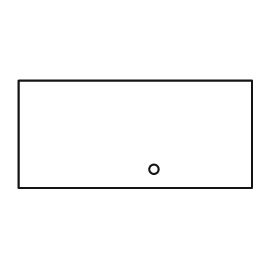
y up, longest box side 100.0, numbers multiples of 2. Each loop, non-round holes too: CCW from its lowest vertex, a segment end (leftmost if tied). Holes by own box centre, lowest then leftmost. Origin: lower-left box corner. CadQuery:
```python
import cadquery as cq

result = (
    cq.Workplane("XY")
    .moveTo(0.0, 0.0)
    .lineTo(100.0, 0.0)
    .lineTo(100.0, 46.0)
    .lineTo(0.0, 46.0)
    .close()
    .moveTo(58.0, 8.0)
    .circle(2.0)
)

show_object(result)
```